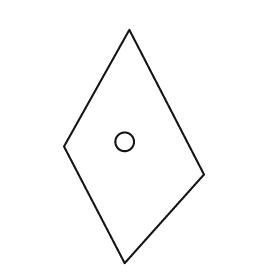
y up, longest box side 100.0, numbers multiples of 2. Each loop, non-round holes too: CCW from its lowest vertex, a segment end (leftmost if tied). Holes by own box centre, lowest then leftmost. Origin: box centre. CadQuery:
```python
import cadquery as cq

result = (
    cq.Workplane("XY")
    .moveTo(-4.0, -50.0)
    .lineTo(30.0, -12.0)
    .lineTo(-2.0, 50.0)
    .lineTo(-30.0, 0.0)
    .close()
    .moveTo(-4.0, 2.0)
    .circle(4.0)
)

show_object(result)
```